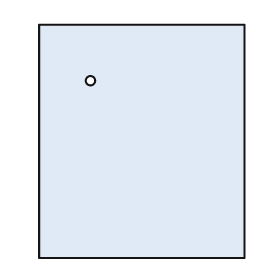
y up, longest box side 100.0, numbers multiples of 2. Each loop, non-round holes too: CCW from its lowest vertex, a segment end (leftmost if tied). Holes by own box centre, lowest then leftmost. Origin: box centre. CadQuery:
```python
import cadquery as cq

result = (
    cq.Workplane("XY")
    .moveTo(-44.0, -50.0)
    .lineTo(44.0, -50.0)
    .lineTo(44.0, 50.0)
    .lineTo(-44.0, 50.0)
    .close()
    .moveTo(-22.0, 26.0)
    .circle(2.0)
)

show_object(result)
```